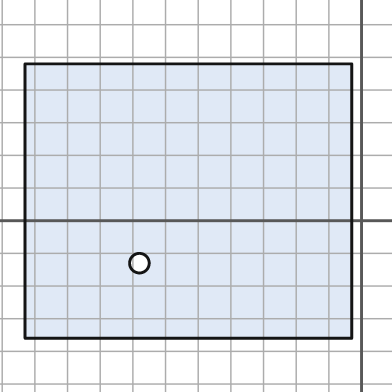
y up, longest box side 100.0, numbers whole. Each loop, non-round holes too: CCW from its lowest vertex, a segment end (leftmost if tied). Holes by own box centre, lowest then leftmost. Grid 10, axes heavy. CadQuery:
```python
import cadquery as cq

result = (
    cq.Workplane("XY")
    .moveTo(-103.0, -36.0)
    .lineTo(-3.0, -36.0)
    .lineTo(-3.0, 48.0)
    .lineTo(-103.0, 48.0)
    .close()
    .moveTo(-68.0, -13.0)
    .circle(3.0)
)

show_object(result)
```